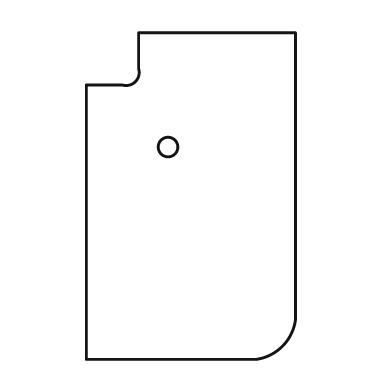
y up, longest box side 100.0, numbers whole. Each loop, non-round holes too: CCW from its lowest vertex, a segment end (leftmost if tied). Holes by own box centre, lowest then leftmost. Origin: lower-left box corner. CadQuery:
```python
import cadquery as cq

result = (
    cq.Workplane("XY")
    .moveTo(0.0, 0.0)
    .lineTo(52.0, 0.0)
    .threePointArc((60.0, 4.0), (64.0, 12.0))
    .lineTo(64.0, 100.0)
    .lineTo(16.0, 100.0)
    .lineTo(16.0, 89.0)
    .threePointArc((15.0, 85.0), (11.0, 84.0))
    .lineTo(0.0, 84.0)
    .close()
    .moveTo(25.0, 65.0)
    .circle(3.0)
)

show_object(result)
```